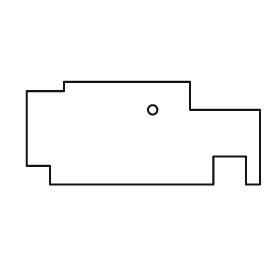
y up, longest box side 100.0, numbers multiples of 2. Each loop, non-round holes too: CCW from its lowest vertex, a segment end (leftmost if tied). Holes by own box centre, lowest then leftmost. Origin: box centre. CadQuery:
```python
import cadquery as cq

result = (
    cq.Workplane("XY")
    .moveTo(-40.0, -22.0)
    .lineTo(30.0, -22.0)
    .lineTo(30.0, -10.0)
    .lineTo(44.0, -10.0)
    .lineTo(44.0, -22.0)
    .lineTo(50.0, -22.0)
    .lineTo(50.0, 10.0)
    .lineTo(20.0, 10.0)
    .lineTo(20.0, 22.0)
    .lineTo(-34.0, 22.0)
    .lineTo(-34.0, 18.0)
    .lineTo(-50.0, 18.0)
    .lineTo(-50.0, -14.0)
    .lineTo(-40.0, -14.0)
    .close()
    .moveTo(4.0, 10.0)
    .circle(2.0)
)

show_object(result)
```